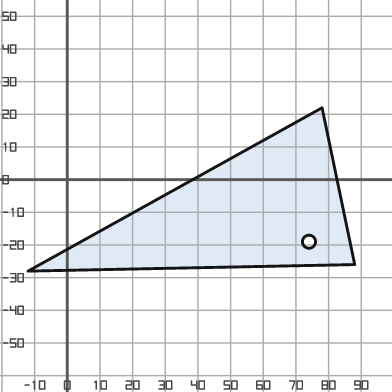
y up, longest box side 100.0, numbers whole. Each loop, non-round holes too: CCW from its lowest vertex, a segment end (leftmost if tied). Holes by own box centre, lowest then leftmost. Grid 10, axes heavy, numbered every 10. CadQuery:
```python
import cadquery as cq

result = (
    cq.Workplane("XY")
    .moveTo(-12.0, -28.0)
    .lineTo(88.0, -26.0)
    .lineTo(78.0, 22.0)
    .close()
    .moveTo(74.0, -19.0)
    .circle(2.0)
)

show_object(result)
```